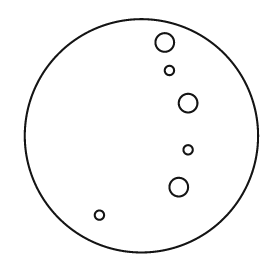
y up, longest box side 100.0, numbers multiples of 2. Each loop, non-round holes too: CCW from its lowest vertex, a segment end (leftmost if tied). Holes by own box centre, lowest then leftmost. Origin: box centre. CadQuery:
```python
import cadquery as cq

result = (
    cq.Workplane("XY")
    .moveTo(0.0, 0.0)
    .circle(50.0)
    .moveTo(-18.0, -34.0)
    .circle(2.0)
    .moveTo(16.0, -22.0)
    .circle(4.0)
    .moveTo(20.0, -6.0)
    .circle(2.0)
    .moveTo(20.0, 14.0)
    .circle(4.0)
    .moveTo(12.0, 28.0)
    .circle(2.0)
    .moveTo(10.0, 40.0)
    .circle(4.0)
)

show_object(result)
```